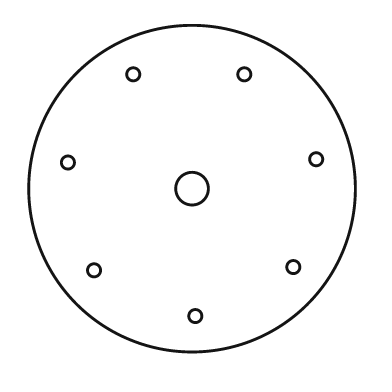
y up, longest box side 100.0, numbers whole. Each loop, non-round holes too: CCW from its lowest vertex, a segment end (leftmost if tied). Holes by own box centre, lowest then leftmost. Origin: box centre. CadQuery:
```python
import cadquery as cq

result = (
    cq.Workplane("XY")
    .moveTo(0.0, 0.0)
    .circle(50.0)
    .moveTo(1.0, -39.0)
    .circle(2.0)
    .moveTo(-30.0, -25.0)
    .circle(2.0)
    .moveTo(31.0, -24.0)
    .circle(2.0)
    .moveTo(0.0, 0.0)
    .circle(5.0)
    .moveTo(-38.0, 8.0)
    .circle(2.0)
    .moveTo(38.0, 9.0)
    .circle(2.0)
    .moveTo(-18.0, 35.0)
    .circle(2.0)
    .moveTo(16.0, 35.0)
    .circle(2.0)
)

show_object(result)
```